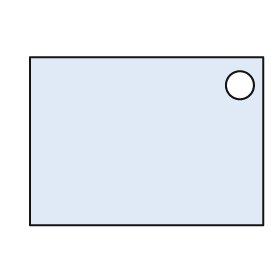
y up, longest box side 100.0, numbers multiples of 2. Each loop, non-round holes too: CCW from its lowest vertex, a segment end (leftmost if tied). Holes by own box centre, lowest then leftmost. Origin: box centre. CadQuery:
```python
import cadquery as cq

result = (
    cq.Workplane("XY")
    .moveTo(-50.0, -36.0)
    .lineTo(50.0, -36.0)
    .lineTo(50.0, 36.0)
    .lineTo(-50.0, 36.0)
    .close()
    .moveTo(40.0, 24.0)
    .circle(6.0)
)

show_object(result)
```